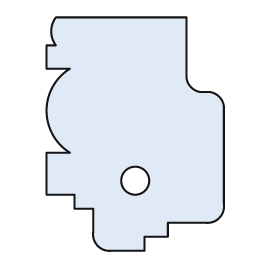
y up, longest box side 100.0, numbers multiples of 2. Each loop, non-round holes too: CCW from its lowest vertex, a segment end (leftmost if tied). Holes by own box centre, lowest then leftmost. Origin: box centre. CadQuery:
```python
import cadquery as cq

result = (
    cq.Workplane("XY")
    .moveTo(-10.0, -50.0)
    .lineTo(4.0, -50.0)
    .lineTo(4.0, -44.0)
    .lineTo(14.0, -44.0)
    .lineTo(14.0, -38.0)
    .lineTo(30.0, -38.0)
    .threePointArc((36.0, -36.0), (38.0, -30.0))
    .lineTo(38.0, 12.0)
    .threePointArc((36.0, 16.0), (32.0, 18.0))
    .lineTo(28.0, 18.0)
    .threePointArc((24.0, 20.0), (22.0, 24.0))
    .lineTo(22.0, 50.0)
    .lineTo(-34.0, 50.0)
    .threePointArc((-36.0, 44.0), (-34.0, 38.0))
    .lineTo(-38.0, 38.0)
    .lineTo(-38.0, 28.0)
    .lineTo(-28.0, 28.0)
    .threePointArc((-38.0, 10.0), (-28.0, -8.0))
    .lineTo(-38.0, -8.0)
    .lineTo(-38.0, -26.0)
    .lineTo(-26.0, -26.0)
    .lineTo(-26.0, -32.0)
    .lineTo(-18.0, -32.0)
    .lineTo(-18.0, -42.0)
    .threePointArc((-16.0, -48.0), (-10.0, -50.0))
    .close()
    .moveTo(0.0, -20.0)
    .circle(6.0)
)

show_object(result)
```